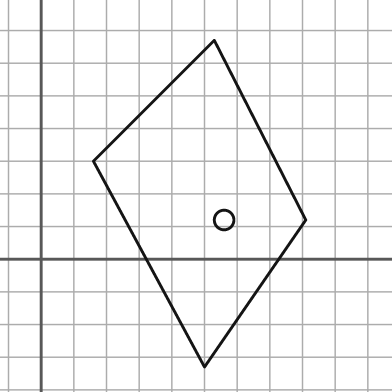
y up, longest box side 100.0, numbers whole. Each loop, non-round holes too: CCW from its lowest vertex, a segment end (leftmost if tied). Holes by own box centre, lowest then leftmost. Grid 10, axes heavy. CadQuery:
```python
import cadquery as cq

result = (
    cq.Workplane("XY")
    .moveTo(50.0, -33.0)
    .lineTo(81.0, 12.0)
    .lineTo(53.0, 67.0)
    .lineTo(16.0, 30.0)
    .close()
    .moveTo(56.0, 12.0)
    .circle(3.0)
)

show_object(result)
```